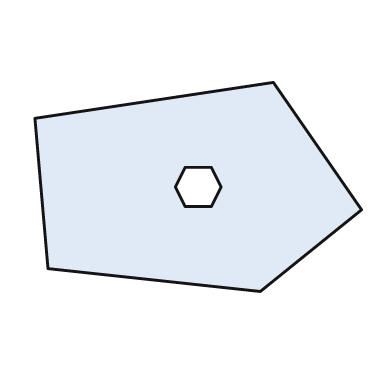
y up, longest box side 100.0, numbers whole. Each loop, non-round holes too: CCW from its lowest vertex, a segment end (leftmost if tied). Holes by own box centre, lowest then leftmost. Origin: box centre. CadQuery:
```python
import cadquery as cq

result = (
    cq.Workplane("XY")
    .moveTo(19.0, -32.0)
    .lineTo(50.0, -7.0)
    .lineTo(23.0, 32.0)
    .lineTo(-50.0, 21.0)
    .lineTo(-46.0, -25.0)
    .close()
    .moveTo(-4.0, -6.0)
    .lineTo(4.0, -6.0)
    .lineTo(7.0, 0.0)
    .lineTo(4.0, 6.0)
    .lineTo(-4.0, 6.0)
    .lineTo(-7.0, 0.0)
    .close()
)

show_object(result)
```